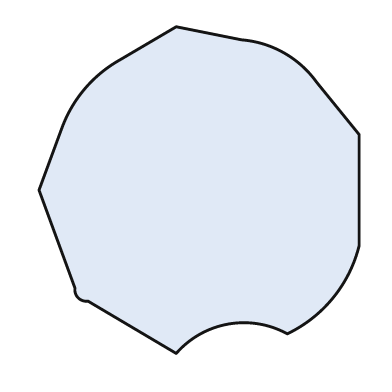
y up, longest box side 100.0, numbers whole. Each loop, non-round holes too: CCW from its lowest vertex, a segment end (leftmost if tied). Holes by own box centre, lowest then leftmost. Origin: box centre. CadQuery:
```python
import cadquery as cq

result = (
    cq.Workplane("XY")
    .moveTo(-7.0, -50.0)
    .threePointArc((9.0, -41.0), (27.0, -44.0))
    .threePointArc((41.0, -33.0), (49.0, -17.0))
    .lineTo(49.0, 17.0)
    .lineTo(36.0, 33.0)
    .threePointArc((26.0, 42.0), (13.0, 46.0))
    .lineTo(-7.0, 50.0)
    .lineTo(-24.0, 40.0)
    .threePointArc((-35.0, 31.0), (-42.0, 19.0))
    .lineTo(-49.0, 0.0)
    .lineTo(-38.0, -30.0)
    .threePointArc((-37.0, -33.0), (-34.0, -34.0))
    .close()
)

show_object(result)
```